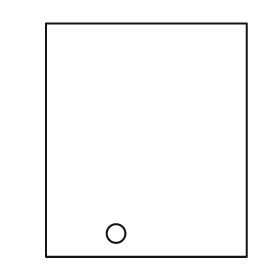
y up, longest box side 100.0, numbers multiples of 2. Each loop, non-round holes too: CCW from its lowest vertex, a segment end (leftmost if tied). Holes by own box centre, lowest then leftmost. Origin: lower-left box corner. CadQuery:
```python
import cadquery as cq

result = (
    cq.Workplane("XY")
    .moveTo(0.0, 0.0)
    .lineTo(86.0, 0.0)
    .lineTo(86.0, 100.0)
    .lineTo(0.0, 100.0)
    .close()
    .moveTo(30.0, 10.0)
    .circle(4.0)
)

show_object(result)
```